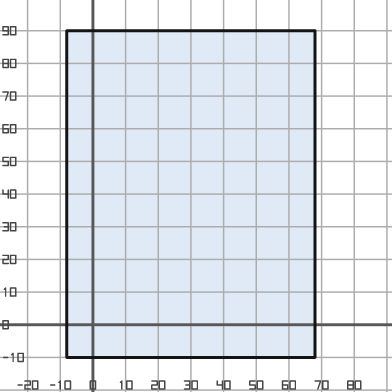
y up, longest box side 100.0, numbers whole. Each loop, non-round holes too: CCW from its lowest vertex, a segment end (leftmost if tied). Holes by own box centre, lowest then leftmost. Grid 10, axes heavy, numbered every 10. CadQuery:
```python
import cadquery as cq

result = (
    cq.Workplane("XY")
    .moveTo(-8.0, -10.0)
    .lineTo(68.0, -10.0)
    .lineTo(68.0, 90.0)
    .lineTo(-8.0, 90.0)
    .close()
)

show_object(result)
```